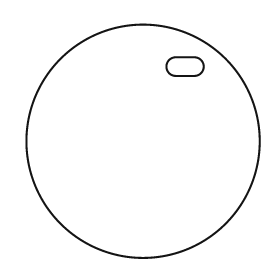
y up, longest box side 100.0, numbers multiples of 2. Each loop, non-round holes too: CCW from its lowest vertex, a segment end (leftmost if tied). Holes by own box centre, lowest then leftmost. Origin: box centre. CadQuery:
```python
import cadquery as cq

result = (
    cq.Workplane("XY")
    .moveTo(0.0, 0.0)
    .circle(50.0)
    .moveTo(14.0, 28.0)
    .lineTo(22.0, 28.0)
    .threePointArc((26.0, 32.0), (22.0, 36.0))
    .lineTo(14.0, 36.0)
    .threePointArc((10.0, 32.0), (14.0, 28.0))
    .close()
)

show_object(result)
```